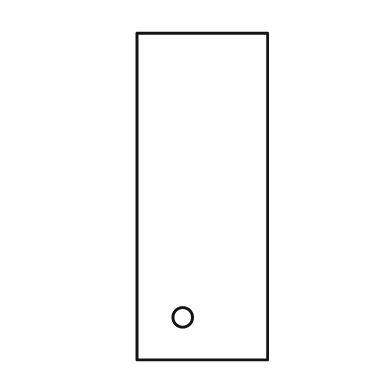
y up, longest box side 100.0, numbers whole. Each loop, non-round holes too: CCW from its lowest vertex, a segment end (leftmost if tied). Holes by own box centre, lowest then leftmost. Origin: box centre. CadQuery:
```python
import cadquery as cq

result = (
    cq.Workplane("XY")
    .moveTo(-20.0, -50.0)
    .lineTo(20.0, -50.0)
    .lineTo(20.0, 50.0)
    .lineTo(-20.0, 50.0)
    .close()
    .moveTo(-6.0, -37.0)
    .circle(3.0)
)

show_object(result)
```